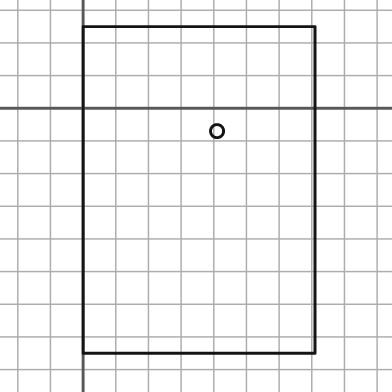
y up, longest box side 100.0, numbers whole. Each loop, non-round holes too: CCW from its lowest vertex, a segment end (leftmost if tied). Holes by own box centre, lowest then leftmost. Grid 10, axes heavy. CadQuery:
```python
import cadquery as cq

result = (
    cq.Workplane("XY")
    .moveTo(0.0, -75.0)
    .lineTo(71.0, -75.0)
    .lineTo(71.0, 25.0)
    .lineTo(0.0, 25.0)
    .close()
    .moveTo(41.0, -7.0)
    .circle(2.0)
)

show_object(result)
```